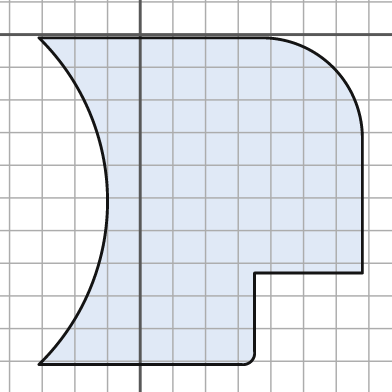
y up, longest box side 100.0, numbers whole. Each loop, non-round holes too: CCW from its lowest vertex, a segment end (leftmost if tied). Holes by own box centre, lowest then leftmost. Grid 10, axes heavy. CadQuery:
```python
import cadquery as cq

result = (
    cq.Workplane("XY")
    .moveTo(-31.0, -101.0)
    .lineTo(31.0, -101.0)
    .threePointArc((34.0, -100.0), (35.0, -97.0))
    .lineTo(35.0, -73.0)
    .lineTo(68.0, -73.0)
    .lineTo(68.0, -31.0)
    .threePointArc((59.0, -10.0), (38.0, -1.0))
    .lineTo(-31.0, -1.0)
    .threePointArc((-10.0, -51.0), (-31.0, -101.0))
    .close()
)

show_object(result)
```